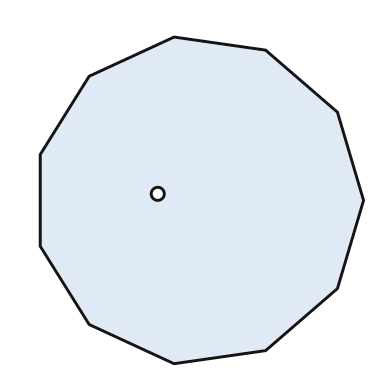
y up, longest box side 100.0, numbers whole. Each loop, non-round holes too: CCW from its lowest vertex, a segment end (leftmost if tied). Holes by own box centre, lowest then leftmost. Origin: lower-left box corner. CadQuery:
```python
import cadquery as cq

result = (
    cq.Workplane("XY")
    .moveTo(41.0, 0.0)
    .lineTo(69.0, 4.0)
    .lineTo(91.0, 23.0)
    .lineTo(99.0, 50.0)
    .lineTo(91.0, 77.0)
    .lineTo(69.0, 96.0)
    .lineTo(41.0, 100.0)
    .lineTo(15.0, 88.0)
    .lineTo(0.0, 64.0)
    .lineTo(0.0, 36.0)
    .lineTo(15.0, 12.0)
    .close()
    .moveTo(36.0, 52.0)
    .circle(2.0)
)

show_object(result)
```